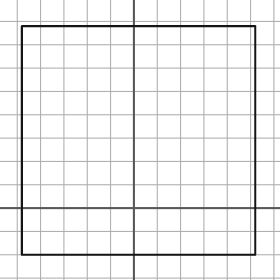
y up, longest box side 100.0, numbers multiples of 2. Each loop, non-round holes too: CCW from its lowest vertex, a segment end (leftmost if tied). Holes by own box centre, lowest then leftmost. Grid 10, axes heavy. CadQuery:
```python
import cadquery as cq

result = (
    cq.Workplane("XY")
    .moveTo(-48.0, -20.0)
    .lineTo(52.0, -20.0)
    .lineTo(52.0, 78.0)
    .lineTo(-48.0, 78.0)
    .close()
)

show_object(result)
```